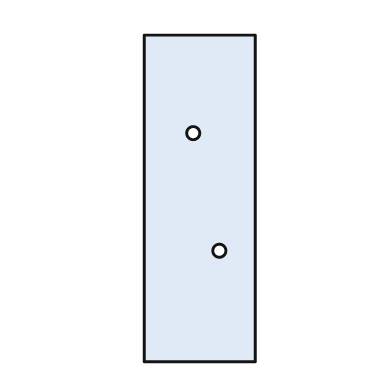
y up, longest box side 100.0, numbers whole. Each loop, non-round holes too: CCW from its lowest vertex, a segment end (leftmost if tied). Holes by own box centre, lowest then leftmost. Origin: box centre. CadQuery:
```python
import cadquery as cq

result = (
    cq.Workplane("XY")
    .moveTo(-17.0, -50.0)
    .lineTo(17.0, -50.0)
    .lineTo(17.0, 50.0)
    .lineTo(-17.0, 50.0)
    .close()
    .moveTo(6.0, -16.0)
    .circle(2.0)
    .moveTo(-2.0, 20.0)
    .circle(2.0)
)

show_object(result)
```